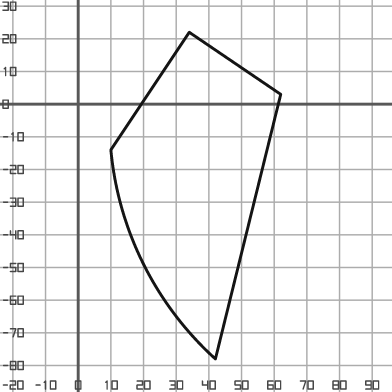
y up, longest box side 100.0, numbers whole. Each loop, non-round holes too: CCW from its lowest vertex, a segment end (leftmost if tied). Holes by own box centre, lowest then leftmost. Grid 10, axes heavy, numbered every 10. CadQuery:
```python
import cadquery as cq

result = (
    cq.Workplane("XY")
    .moveTo(42.0, -78.0)
    .lineTo(62.0, 3.0)
    .lineTo(34.0, 22.0)
    .lineTo(10.0, -14.0)
    .threePointArc((20.0, -49.0), (42.0, -78.0))
    .close()
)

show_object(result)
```